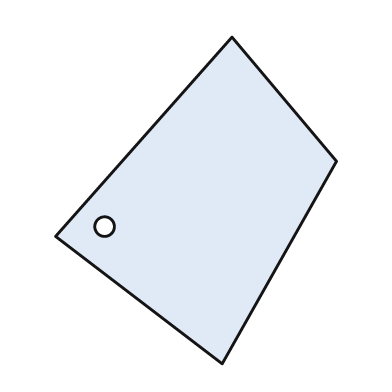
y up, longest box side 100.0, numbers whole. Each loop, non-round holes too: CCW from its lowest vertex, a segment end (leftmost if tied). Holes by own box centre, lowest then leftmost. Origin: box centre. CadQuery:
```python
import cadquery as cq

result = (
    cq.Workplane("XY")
    .moveTo(8.0, -50.0)
    .lineTo(43.0, 12.0)
    .lineTo(11.0, 50.0)
    .lineTo(-43.0, -11.0)
    .close()
    .moveTo(-28.0, -8.0)
    .circle(3.0)
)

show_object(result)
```